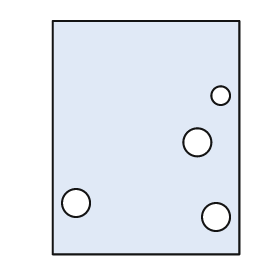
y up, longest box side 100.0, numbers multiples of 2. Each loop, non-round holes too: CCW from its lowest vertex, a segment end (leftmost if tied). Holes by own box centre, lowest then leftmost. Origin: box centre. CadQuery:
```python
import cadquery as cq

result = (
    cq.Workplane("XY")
    .moveTo(-40.0, -50.0)
    .lineTo(40.0, -50.0)
    .lineTo(40.0, 50.0)
    .lineTo(-40.0, 50.0)
    .close()
    .moveTo(30.0, -34.0)
    .circle(6.0)
    .moveTo(-30.0, -28.0)
    .circle(6.0)
    .moveTo(22.0, -2.0)
    .circle(6.0)
    .moveTo(32.0, 18.0)
    .circle(4.0)
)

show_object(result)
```